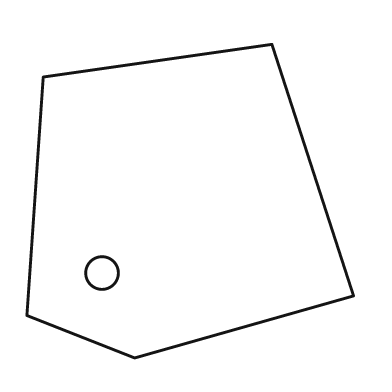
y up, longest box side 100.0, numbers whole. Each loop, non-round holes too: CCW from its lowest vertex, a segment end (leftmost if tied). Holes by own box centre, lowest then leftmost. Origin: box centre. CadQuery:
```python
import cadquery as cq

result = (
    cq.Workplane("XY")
    .moveTo(-17.0, -48.0)
    .lineTo(50.0, -29.0)
    .lineTo(25.0, 48.0)
    .lineTo(-45.0, 38.0)
    .lineTo(-50.0, -35.0)
    .close()
    .moveTo(-27.0, -22.0)
    .circle(5.0)
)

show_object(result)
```